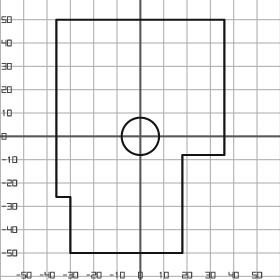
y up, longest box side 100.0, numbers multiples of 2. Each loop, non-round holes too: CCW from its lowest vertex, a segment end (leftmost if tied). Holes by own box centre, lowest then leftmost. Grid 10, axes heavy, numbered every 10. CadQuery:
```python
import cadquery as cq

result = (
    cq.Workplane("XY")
    .moveTo(-30.0, -50.0)
    .lineTo(18.0, -50.0)
    .lineTo(18.0, -8.0)
    .lineTo(36.0, -8.0)
    .lineTo(36.0, 50.0)
    .lineTo(-36.0, 50.0)
    .lineTo(-36.0, -26.0)
    .lineTo(-30.0, -26.0)
    .close()
    .moveTo(0.0, 0.0)
    .circle(8.0)
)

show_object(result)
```